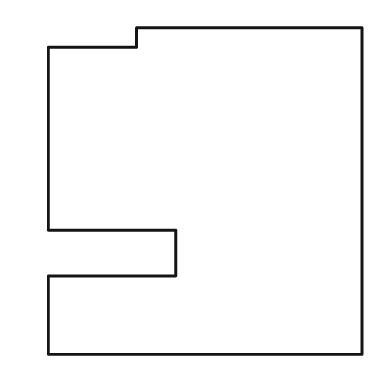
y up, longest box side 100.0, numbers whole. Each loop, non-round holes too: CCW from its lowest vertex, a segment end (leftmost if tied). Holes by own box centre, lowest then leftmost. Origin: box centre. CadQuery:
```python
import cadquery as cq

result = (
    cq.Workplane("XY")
    .moveTo(-48.0, -50.0)
    .lineTo(48.0, -50.0)
    .lineTo(48.0, 50.0)
    .lineTo(-21.0, 50.0)
    .lineTo(-21.0, 44.0)
    .lineTo(-48.0, 44.0)
    .lineTo(-48.0, -12.0)
    .lineTo(-9.0, -12.0)
    .lineTo(-9.0, -26.0)
    .lineTo(-48.0, -26.0)
    .close()
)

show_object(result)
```